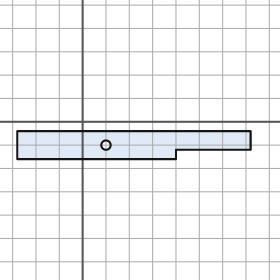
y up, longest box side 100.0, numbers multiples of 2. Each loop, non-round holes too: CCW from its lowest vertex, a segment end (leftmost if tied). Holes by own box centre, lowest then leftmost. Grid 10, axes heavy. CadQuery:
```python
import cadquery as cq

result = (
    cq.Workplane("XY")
    .moveTo(-28.0, -16.0)
    .lineTo(40.0, -16.0)
    .lineTo(40.0, -12.0)
    .lineTo(72.0, -12.0)
    .lineTo(72.0, -4.0)
    .lineTo(-28.0, -4.0)
    .close()
    .moveTo(10.0, -10.0)
    .circle(2.0)
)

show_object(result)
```